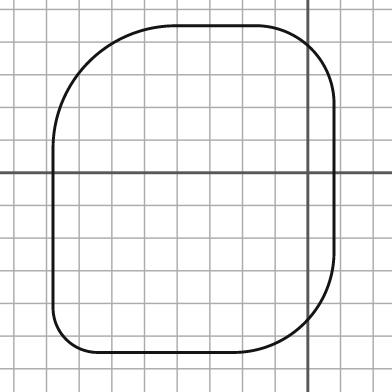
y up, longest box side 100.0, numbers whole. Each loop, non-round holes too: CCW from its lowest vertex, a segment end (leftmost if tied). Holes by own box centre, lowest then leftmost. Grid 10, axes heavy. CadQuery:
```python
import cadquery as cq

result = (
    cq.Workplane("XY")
    .moveTo(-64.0, -55.0)
    .lineTo(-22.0, -55.0)
    .threePointArc((-1.0, -46.0), (8.0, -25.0))
    .lineTo(8.0, 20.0)
    .threePointArc((1.0, 38.0), (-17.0, 45.0))
    .lineTo(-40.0, 45.0)
    .threePointArc((-67.0, 34.0), (-78.0, 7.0))
    .lineTo(-78.0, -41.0)
    .threePointArc((-74.0, -51.0), (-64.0, -55.0))
    .close()
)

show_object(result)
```